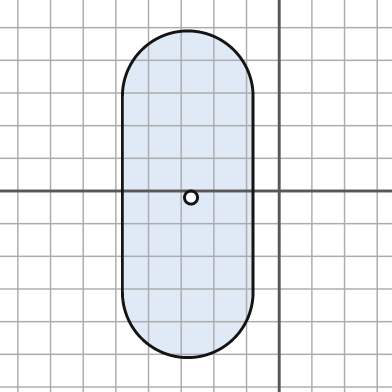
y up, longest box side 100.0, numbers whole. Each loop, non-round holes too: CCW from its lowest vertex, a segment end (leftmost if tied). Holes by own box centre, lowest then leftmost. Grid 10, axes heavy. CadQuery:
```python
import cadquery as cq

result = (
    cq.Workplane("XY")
    .moveTo(-48.0, -31.0)
    .threePointArc((-28.0, -51.0), (-8.0, -31.0))
    .lineTo(-8.0, 29.0)
    .threePointArc((-28.0, 49.0), (-48.0, 29.0))
    .close()
    .moveTo(-27.0, -2.0)
    .circle(2.0)
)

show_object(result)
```